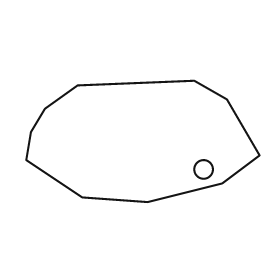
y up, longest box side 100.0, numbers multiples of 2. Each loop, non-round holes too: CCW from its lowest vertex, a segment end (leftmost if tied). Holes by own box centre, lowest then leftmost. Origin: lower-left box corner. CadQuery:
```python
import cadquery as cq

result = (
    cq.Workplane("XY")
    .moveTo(52.0, 0.0)
    .lineTo(84.0, 8.0)
    .lineTo(100.0, 20.0)
    .lineTo(86.0, 44.0)
    .lineTo(72.0, 52.0)
    .lineTo(22.0, 50.0)
    .lineTo(8.0, 40.0)
    .lineTo(2.0, 30.0)
    .lineTo(0.0, 18.0)
    .lineTo(24.0, 2.0)
    .close()
    .moveTo(76.0, 14.0)
    .circle(4.0)
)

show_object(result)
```